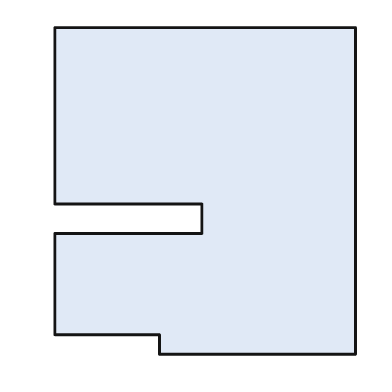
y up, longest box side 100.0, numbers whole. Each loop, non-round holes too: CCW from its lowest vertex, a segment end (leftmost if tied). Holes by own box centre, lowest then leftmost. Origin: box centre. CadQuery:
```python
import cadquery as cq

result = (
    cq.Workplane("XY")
    .moveTo(-14.0, -50.0)
    .lineTo(46.0, -50.0)
    .lineTo(46.0, 50.0)
    .lineTo(-46.0, 50.0)
    .lineTo(-46.0, -4.0)
    .lineTo(-1.0, -4.0)
    .lineTo(-1.0, -13.0)
    .lineTo(-46.0, -13.0)
    .lineTo(-46.0, -44.0)
    .lineTo(-14.0, -44.0)
    .close()
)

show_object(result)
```